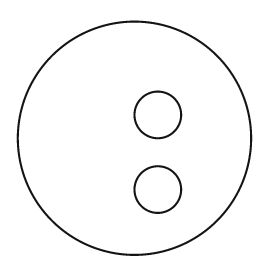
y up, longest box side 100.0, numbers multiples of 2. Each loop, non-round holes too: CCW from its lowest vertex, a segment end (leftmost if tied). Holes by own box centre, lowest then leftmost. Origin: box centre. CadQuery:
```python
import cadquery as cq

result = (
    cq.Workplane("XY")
    .moveTo(0.0, 0.0)
    .circle(50.0)
    .moveTo(10.0, -22.0)
    .circle(10.0)
    .moveTo(10.0, 10.0)
    .circle(10.0)
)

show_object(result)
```